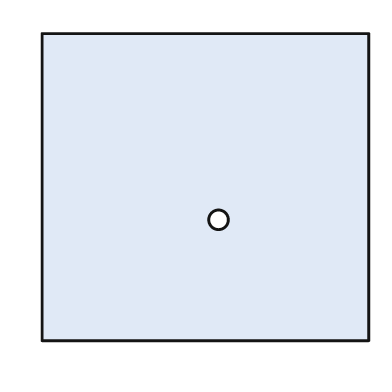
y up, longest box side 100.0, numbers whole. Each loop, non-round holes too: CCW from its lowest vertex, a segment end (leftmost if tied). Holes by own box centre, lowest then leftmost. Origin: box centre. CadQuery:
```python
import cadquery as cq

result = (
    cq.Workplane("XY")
    .moveTo(-50.0, -47.0)
    .lineTo(50.0, -47.0)
    .lineTo(50.0, 47.0)
    .lineTo(-50.0, 47.0)
    .close()
    .moveTo(4.0, -10.0)
    .circle(3.0)
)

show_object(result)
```